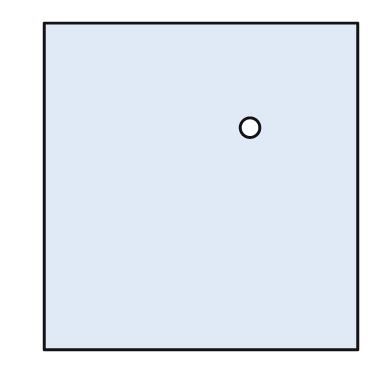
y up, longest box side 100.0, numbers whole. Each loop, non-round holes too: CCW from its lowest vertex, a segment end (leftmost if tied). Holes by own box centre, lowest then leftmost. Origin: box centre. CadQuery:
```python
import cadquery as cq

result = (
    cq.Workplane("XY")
    .moveTo(-48.0, -50.0)
    .lineTo(48.0, -50.0)
    .lineTo(48.0, 50.0)
    .lineTo(-48.0, 50.0)
    .close()
    .moveTo(15.0, 18.0)
    .circle(3.0)
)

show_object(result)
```